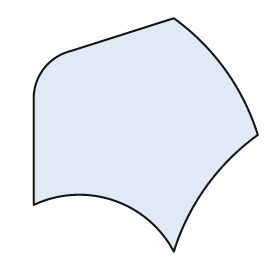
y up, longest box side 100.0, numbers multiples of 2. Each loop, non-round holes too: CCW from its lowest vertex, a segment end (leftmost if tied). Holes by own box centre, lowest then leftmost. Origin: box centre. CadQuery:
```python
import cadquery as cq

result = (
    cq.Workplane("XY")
    .moveTo(12.0, -50.0)
    .threePointArc((26.0, -22.0), (48.0, 0.0))
    .threePointArc((34.0, 28.0), (12.0, 50.0))
    .lineTo(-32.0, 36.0)
    .threePointArc((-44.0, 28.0), (-48.0, 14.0))
    .lineTo(-48.0, -30.0)
    .threePointArc((-14.0, -28.0), (12.0, -50.0))
    .close()
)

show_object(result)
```